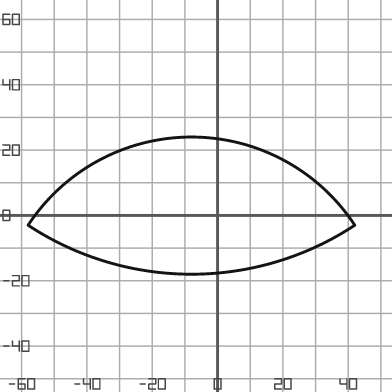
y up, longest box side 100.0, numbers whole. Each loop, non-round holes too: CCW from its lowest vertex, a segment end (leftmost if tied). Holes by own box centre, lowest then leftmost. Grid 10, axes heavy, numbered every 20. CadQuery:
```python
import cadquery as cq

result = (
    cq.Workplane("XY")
    .moveTo(-58.0, -3.0)
    .threePointArc((-8.0, -18.0), (42.0, -3.0))
    .threePointArc((-8.0, 24.0), (-58.0, -3.0))
    .close()
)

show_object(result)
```